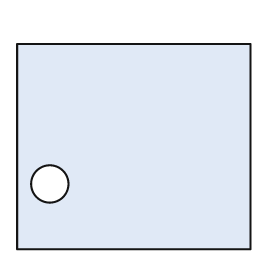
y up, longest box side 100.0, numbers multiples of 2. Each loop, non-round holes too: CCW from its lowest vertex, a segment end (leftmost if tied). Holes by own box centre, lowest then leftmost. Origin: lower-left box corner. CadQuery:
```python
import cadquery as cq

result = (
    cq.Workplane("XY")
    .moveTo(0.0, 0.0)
    .lineTo(100.0, 0.0)
    .lineTo(100.0, 88.0)
    .lineTo(0.0, 88.0)
    .close()
    .moveTo(14.0, 28.0)
    .circle(8.0)
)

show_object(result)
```